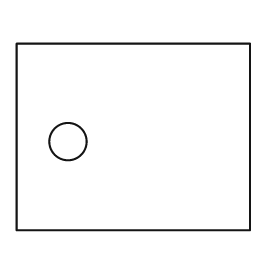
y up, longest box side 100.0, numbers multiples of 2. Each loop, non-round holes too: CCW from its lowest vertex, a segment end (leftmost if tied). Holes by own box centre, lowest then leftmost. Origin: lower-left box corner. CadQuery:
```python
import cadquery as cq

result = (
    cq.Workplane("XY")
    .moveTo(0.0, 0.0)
    .lineTo(100.0, 0.0)
    .lineTo(100.0, 80.0)
    .lineTo(0.0, 80.0)
    .close()
    .moveTo(22.0, 38.0)
    .circle(8.0)
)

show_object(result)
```